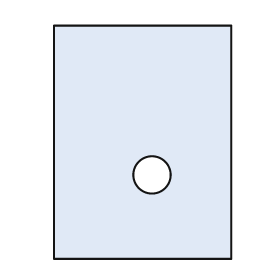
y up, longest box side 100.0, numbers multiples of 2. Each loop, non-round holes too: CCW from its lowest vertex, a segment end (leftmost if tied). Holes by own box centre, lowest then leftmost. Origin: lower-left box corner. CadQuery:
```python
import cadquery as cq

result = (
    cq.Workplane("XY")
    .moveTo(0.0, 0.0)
    .lineTo(76.0, 0.0)
    .lineTo(76.0, 100.0)
    .lineTo(0.0, 100.0)
    .close()
    .moveTo(42.0, 36.0)
    .circle(8.0)
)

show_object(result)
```